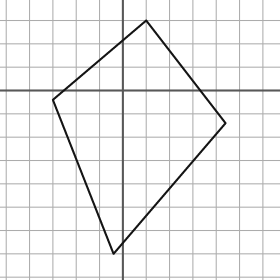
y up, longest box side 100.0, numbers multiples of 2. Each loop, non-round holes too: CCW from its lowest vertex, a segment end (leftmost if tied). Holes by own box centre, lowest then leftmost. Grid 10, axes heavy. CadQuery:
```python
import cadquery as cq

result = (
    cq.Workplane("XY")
    .moveTo(-4.0, -70.0)
    .lineTo(44.0, -14.0)
    .lineTo(10.0, 30.0)
    .lineTo(-30.0, -4.0)
    .close()
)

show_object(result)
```